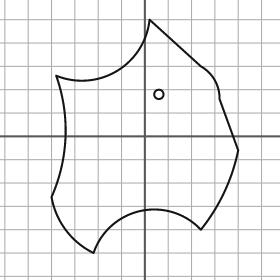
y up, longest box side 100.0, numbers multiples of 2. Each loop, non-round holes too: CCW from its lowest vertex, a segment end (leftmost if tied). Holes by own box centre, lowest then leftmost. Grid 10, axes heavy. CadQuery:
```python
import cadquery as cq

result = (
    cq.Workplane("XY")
    .moveTo(-22.0, -50.0)
    .threePointArc((-2.0, -32.0), (24.0, -40.0))
    .threePointArc((34.0, -24.0), (40.0, -6.0))
    .lineTo(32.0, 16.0)
    .threePointArc((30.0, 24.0), (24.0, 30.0))
    .lineTo(2.0, 50.0)
    .threePointArc((-12.0, 28.0), (-38.0, 26.0))
    .threePointArc((-34.0, 0.0), (-40.0, -26.0))
    .threePointArc((-34.0, -40.0), (-22.0, -50.0))
    .close()
    .moveTo(6.0, 18.0)
    .circle(2.0)
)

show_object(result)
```